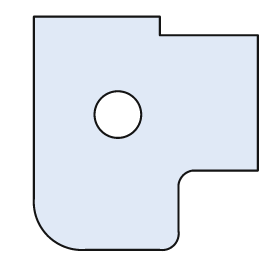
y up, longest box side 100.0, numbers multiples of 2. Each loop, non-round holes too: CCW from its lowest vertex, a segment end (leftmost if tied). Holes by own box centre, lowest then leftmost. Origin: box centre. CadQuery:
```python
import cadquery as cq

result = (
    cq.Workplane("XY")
    .moveTo(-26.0, -50.0)
    .lineTo(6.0, -50.0)
    .threePointArc((12.0, -48.0), (14.0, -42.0))
    .lineTo(14.0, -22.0)
    .threePointArc((16.0, -18.0), (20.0, -16.0))
    .lineTo(48.0, -16.0)
    .lineTo(48.0, 42.0)
    .lineTo(6.0, 42.0)
    .lineTo(6.0, 50.0)
    .lineTo(-48.0, 50.0)
    .lineTo(-48.0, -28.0)
    .threePointArc((-42.0, -44.0), (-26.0, -50.0))
    .close()
    .moveTo(-12.0, 8.0)
    .circle(10.0)
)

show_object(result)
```